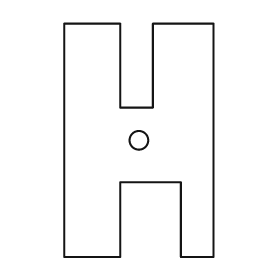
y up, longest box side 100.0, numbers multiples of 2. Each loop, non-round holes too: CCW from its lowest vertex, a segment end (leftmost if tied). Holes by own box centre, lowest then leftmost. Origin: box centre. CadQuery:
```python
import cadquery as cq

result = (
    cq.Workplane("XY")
    .moveTo(-32.0, -50.0)
    .lineTo(-8.0, -50.0)
    .lineTo(-8.0, -18.0)
    .lineTo(18.0, -18.0)
    .lineTo(18.0, -50.0)
    .lineTo(32.0, -50.0)
    .lineTo(32.0, 50.0)
    .lineTo(6.0, 50.0)
    .lineTo(6.0, 14.0)
    .lineTo(-8.0, 14.0)
    .lineTo(-8.0, 50.0)
    .lineTo(-32.0, 50.0)
    .close()
    .moveTo(0.0, 0.0)
    .circle(4.0)
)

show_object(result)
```